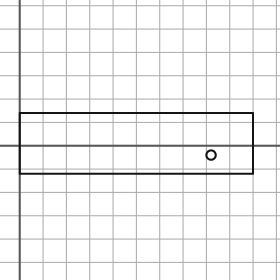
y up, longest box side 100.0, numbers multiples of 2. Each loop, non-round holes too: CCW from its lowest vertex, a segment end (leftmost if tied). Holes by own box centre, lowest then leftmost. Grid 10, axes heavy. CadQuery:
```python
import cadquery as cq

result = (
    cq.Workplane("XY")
    .moveTo(0.0, -12.0)
    .lineTo(100.0, -12.0)
    .lineTo(100.0, 14.0)
    .lineTo(0.0, 14.0)
    .close()
    .moveTo(82.0, -4.0)
    .circle(2.0)
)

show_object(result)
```